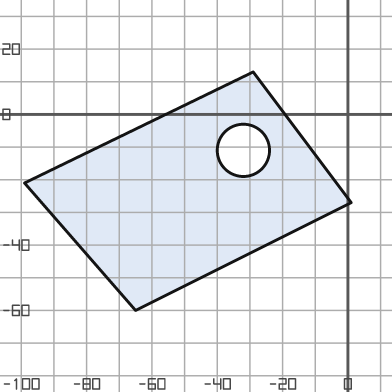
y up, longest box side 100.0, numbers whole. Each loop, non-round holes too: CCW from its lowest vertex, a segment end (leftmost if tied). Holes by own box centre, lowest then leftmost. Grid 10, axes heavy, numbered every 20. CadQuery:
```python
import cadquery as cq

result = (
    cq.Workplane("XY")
    .moveTo(-65.0, -60.0)
    .lineTo(1.0, -27.0)
    .lineTo(-29.0, 13.0)
    .lineTo(-99.0, -21.0)
    .close()
    .moveTo(-32.0, -11.0)
    .circle(8.0)
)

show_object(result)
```